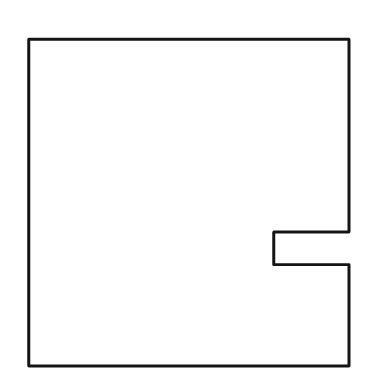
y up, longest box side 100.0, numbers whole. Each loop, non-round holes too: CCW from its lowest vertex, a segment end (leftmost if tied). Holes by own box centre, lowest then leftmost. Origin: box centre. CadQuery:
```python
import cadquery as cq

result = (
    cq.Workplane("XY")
    .moveTo(-49.0, -50.0)
    .lineTo(49.0, -50.0)
    .lineTo(49.0, -19.0)
    .lineTo(26.0, -19.0)
    .lineTo(26.0, -9.0)
    .lineTo(49.0, -9.0)
    .lineTo(49.0, 50.0)
    .lineTo(-49.0, 50.0)
    .close()
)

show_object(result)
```